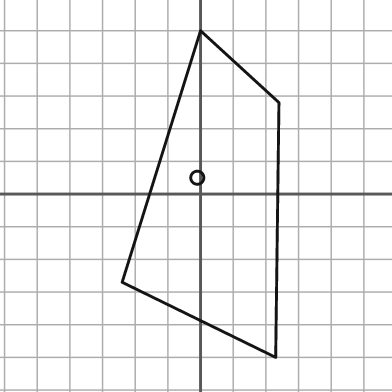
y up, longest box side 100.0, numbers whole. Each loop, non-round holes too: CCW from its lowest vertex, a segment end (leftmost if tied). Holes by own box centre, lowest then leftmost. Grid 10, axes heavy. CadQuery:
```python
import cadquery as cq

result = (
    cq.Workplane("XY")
    .moveTo(23.0, -50.0)
    .lineTo(24.0, 28.0)
    .lineTo(0.0, 50.0)
    .lineTo(-24.0, -27.0)
    .close()
    .moveTo(-1.0, 5.0)
    .circle(2.0)
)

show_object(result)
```